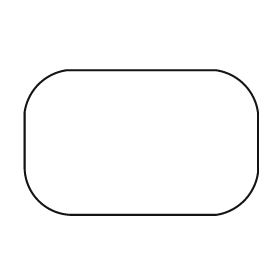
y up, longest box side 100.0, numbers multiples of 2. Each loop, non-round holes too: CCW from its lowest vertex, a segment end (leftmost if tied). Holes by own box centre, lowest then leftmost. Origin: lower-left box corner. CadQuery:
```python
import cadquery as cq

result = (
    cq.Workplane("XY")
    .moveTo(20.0, 0.0)
    .lineTo(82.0, 0.0)
    .threePointArc((94.0, 6.0), (100.0, 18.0))
    .lineTo(100.0, 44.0)
    .threePointArc((94.0, 56.0), (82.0, 62.0))
    .lineTo(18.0, 62.0)
    .threePointArc((6.0, 56.0), (0.0, 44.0))
    .lineTo(0.0, 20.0)
    .threePointArc((6.0, 6.0), (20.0, 0.0))
    .close()
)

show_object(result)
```